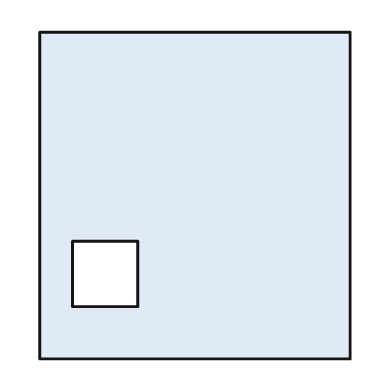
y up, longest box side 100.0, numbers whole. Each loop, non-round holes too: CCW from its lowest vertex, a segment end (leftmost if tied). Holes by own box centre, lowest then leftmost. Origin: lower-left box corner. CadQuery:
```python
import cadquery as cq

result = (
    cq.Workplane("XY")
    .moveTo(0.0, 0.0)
    .lineTo(95.0, 0.0)
    .lineTo(95.0, 100.0)
    .lineTo(0.0, 100.0)
    .close()
    .moveTo(10.0, 16.0)
    .lineTo(30.0, 16.0)
    .lineTo(30.0, 36.0)
    .lineTo(10.0, 36.0)
    .close()
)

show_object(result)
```